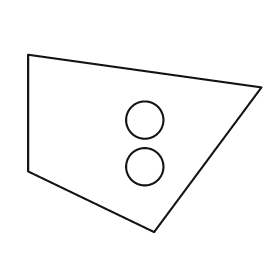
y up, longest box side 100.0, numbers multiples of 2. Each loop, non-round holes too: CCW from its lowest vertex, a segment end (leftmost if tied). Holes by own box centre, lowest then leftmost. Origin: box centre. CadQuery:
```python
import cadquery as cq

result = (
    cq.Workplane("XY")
    .moveTo(4.0, -38.0)
    .lineTo(50.0, 24.0)
    .lineTo(-50.0, 38.0)
    .lineTo(-50.0, -12.0)
    .close()
    .moveTo(0.0, -10.0)
    .circle(8.0)
    .moveTo(0.0, 10.0)
    .circle(8.0)
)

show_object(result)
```